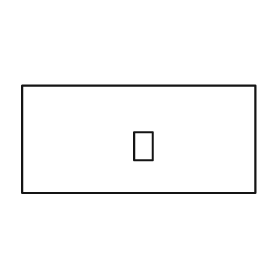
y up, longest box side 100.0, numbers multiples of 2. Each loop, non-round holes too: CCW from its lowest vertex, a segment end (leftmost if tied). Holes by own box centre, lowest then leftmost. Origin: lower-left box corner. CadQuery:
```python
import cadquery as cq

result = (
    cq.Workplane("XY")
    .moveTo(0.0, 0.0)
    .lineTo(100.0, 0.0)
    .lineTo(100.0, 46.0)
    .lineTo(0.0, 46.0)
    .close()
    .moveTo(48.0, 14.0)
    .lineTo(56.0, 14.0)
    .lineTo(56.0, 26.0)
    .lineTo(48.0, 26.0)
    .close()
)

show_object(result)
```